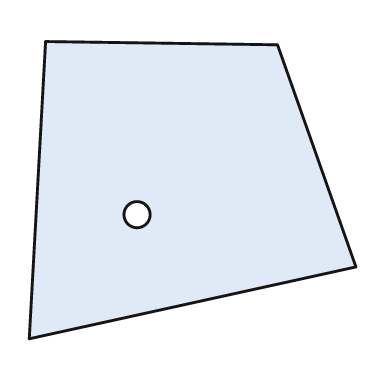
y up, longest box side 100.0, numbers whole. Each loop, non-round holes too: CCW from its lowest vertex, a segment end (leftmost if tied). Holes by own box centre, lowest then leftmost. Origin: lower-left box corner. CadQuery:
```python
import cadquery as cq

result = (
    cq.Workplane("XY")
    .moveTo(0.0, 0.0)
    .lineTo(100.0, 22.0)
    .lineTo(76.0, 90.0)
    .lineTo(5.0, 91.0)
    .close()
    .moveTo(33.0, 38.0)
    .circle(4.0)
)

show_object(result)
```